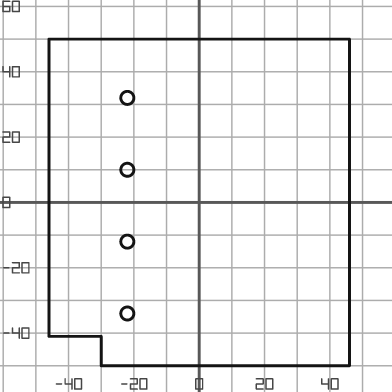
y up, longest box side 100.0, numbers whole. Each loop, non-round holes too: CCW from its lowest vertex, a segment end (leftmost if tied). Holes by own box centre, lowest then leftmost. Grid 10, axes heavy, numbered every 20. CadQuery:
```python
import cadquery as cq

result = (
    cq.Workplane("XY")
    .moveTo(-30.0, -50.0)
    .lineTo(46.0, -50.0)
    .lineTo(46.0, 50.0)
    .lineTo(-46.0, 50.0)
    .lineTo(-46.0, -41.0)
    .lineTo(-30.0, -41.0)
    .close()
    .moveTo(-22.0, -34.0)
    .circle(2.0)
    .moveTo(-22.0, -12.0)
    .circle(2.0)
    .moveTo(-22.0, 10.0)
    .circle(2.0)
    .moveTo(-22.0, 32.0)
    .circle(2.0)
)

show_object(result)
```